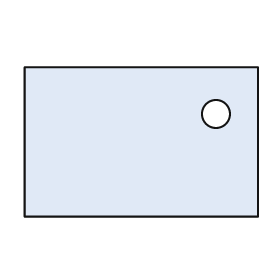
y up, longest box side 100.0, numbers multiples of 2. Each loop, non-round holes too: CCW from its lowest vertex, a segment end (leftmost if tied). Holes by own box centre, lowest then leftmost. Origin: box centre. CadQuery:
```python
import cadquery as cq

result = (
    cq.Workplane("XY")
    .moveTo(-50.0, -32.0)
    .lineTo(50.0, -32.0)
    .lineTo(50.0, 32.0)
    .lineTo(-50.0, 32.0)
    .close()
    .moveTo(32.0, 12.0)
    .circle(6.0)
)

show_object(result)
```